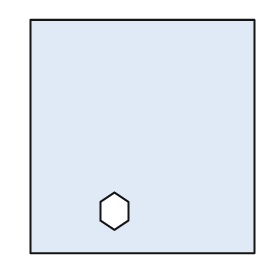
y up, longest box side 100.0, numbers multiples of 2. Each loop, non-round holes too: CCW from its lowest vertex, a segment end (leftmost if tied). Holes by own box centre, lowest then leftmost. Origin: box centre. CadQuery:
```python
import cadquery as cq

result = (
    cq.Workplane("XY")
    .moveTo(-48.0, -50.0)
    .lineTo(48.0, -50.0)
    .lineTo(48.0, 50.0)
    .lineTo(-48.0, 50.0)
    .close()
    .moveTo(-12.0, -40.0)
    .lineTo(-6.0, -36.0)
    .lineTo(-6.0, -28.0)
    .lineTo(-12.0, -24.0)
    .lineTo(-18.0, -28.0)
    .lineTo(-18.0, -36.0)
    .close()
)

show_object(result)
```